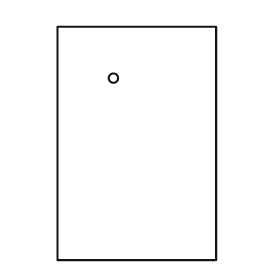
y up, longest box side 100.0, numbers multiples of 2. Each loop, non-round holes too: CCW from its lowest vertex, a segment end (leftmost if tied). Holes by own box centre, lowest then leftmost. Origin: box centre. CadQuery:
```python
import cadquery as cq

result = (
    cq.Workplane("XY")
    .moveTo(-34.0, -50.0)
    .lineTo(34.0, -50.0)
    .lineTo(34.0, 50.0)
    .lineTo(-34.0, 50.0)
    .close()
    .moveTo(-10.0, 28.0)
    .circle(2.0)
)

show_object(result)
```